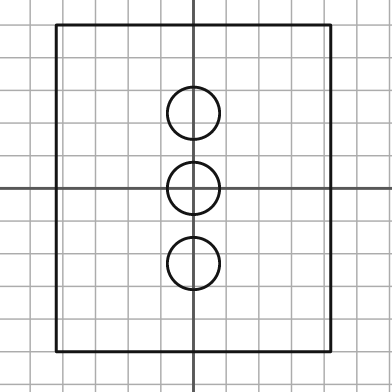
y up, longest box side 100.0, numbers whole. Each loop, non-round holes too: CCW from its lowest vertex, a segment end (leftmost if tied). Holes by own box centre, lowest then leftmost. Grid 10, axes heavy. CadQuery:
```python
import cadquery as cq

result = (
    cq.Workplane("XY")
    .moveTo(-42.0, -50.0)
    .lineTo(42.0, -50.0)
    .lineTo(42.0, 50.0)
    .lineTo(-42.0, 50.0)
    .close()
    .moveTo(0.0, -23.0)
    .circle(8.0)
    .moveTo(0.0, 0.0)
    .circle(8.0)
    .moveTo(0.0, 23.0)
    .circle(8.0)
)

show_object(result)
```